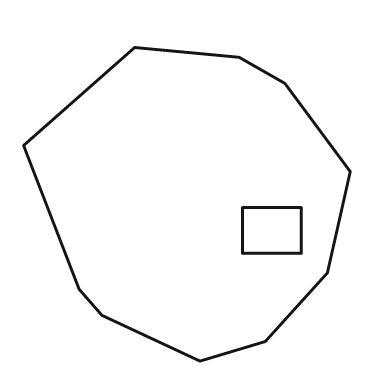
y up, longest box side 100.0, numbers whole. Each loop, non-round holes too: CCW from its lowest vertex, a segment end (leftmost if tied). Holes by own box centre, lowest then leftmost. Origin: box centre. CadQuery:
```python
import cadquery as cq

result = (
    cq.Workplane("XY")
    .moveTo(4.0, -48.0)
    .lineTo(24.0, -42.0)
    .lineTo(43.0, -21.0)
    .lineTo(50.0, 10.0)
    .lineTo(30.0, 37.0)
    .lineTo(16.0, 45.0)
    .lineTo(-16.0, 48.0)
    .lineTo(-50.0, 18.0)
    .lineTo(-33.0, -26.0)
    .lineTo(-26.0, -34.0)
    .close()
    .moveTo(17.0, -15.0)
    .lineTo(35.0, -15.0)
    .lineTo(35.0, -1.0)
    .lineTo(17.0, -1.0)
    .close()
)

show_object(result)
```